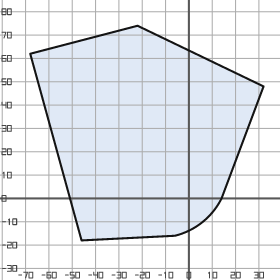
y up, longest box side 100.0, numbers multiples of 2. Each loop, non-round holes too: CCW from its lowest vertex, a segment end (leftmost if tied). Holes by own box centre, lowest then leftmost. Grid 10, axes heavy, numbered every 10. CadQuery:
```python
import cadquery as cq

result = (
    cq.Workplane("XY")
    .moveTo(-46.0, -18.0)
    .lineTo(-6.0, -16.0)
    .threePointArc((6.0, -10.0), (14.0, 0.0))
    .lineTo(32.0, 48.0)
    .lineTo(-22.0, 74.0)
    .lineTo(-68.0, 62.0)
    .close()
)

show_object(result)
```